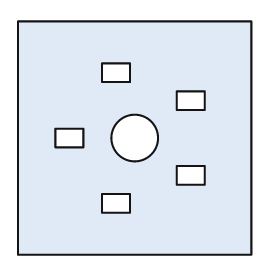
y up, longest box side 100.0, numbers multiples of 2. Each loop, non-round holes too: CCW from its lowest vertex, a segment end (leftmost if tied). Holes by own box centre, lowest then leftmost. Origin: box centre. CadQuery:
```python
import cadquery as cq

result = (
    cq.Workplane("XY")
    .moveTo(-50.0, -50.0)
    .lineTo(50.0, -50.0)
    .lineTo(50.0, 50.0)
    .lineTo(-50.0, 50.0)
    .close()
    .moveTo(-14.0, -32.0)
    .lineTo(-2.0, -32.0)
    .lineTo(-2.0, -24.0)
    .lineTo(-14.0, -24.0)
    .close()
    .moveTo(18.0, -20.0)
    .lineTo(30.0, -20.0)
    .lineTo(30.0, -12.0)
    .lineTo(18.0, -12.0)
    .close()
    .moveTo(-34.0, -4.0)
    .lineTo(-22.0, -4.0)
    .lineTo(-22.0, 4.0)
    .lineTo(-34.0, 4.0)
    .close()
    .moveTo(0.0, 0.0)
    .circle(10.0)
    .moveTo(18.0, 12.0)
    .lineTo(30.0, 12.0)
    .lineTo(30.0, 20.0)
    .lineTo(18.0, 20.0)
    .close()
    .moveTo(-14.0, 24.0)
    .lineTo(-2.0, 24.0)
    .lineTo(-2.0, 32.0)
    .lineTo(-14.0, 32.0)
    .close()
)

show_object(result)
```